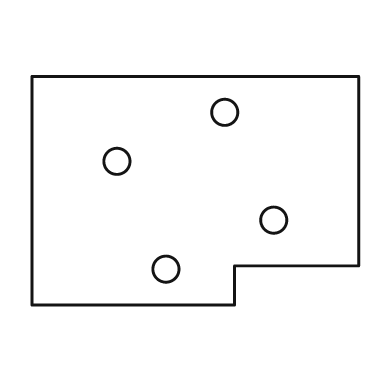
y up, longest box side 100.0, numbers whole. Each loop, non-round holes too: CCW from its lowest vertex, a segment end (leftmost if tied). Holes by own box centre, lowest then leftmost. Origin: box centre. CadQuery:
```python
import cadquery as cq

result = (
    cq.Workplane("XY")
    .moveTo(-50.0, -35.0)
    .lineTo(12.0, -35.0)
    .lineTo(12.0, -23.0)
    .lineTo(50.0, -23.0)
    .lineTo(50.0, 35.0)
    .lineTo(-50.0, 35.0)
    .close()
    .moveTo(-9.0, -24.0)
    .circle(4.0)
    .moveTo(24.0, -9.0)
    .circle(4.0)
    .moveTo(-24.0, 9.0)
    .circle(4.0)
    .moveTo(9.0, 24.0)
    .circle(4.0)
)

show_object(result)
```